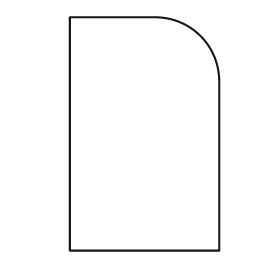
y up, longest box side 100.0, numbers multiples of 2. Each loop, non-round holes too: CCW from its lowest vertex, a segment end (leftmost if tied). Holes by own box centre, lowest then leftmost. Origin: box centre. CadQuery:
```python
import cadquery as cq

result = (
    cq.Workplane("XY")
    .moveTo(-32.0, -50.0)
    .lineTo(32.0, -50.0)
    .lineTo(32.0, 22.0)
    .threePointArc((24.0, 42.0), (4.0, 50.0))
    .lineTo(-32.0, 50.0)
    .close()
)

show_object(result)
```